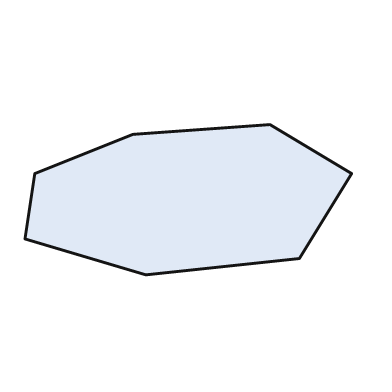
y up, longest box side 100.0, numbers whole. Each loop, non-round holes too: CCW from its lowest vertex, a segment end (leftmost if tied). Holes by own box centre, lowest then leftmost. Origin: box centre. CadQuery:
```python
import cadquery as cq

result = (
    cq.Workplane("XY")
    .moveTo(-13.0, -23.0)
    .lineTo(34.0, -18.0)
    .lineTo(50.0, 8.0)
    .lineTo(25.0, 23.0)
    .lineTo(-17.0, 20.0)
    .lineTo(-47.0, 8.0)
    .lineTo(-50.0, -12.0)
    .close()
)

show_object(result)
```